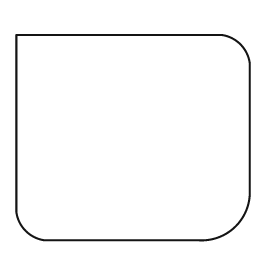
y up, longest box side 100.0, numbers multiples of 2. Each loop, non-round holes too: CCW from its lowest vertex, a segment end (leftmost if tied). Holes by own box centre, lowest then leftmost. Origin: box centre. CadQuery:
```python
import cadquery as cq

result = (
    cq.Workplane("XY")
    .moveTo(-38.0, -44.0)
    .lineTo(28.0, -44.0)
    .threePointArc((44.0, -38.0), (50.0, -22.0))
    .lineTo(50.0, 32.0)
    .threePointArc((46.0, 40.0), (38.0, 44.0))
    .lineTo(-50.0, 44.0)
    .lineTo(-50.0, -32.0)
    .threePointArc((-46.0, -40.0), (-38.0, -44.0))
    .close()
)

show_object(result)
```